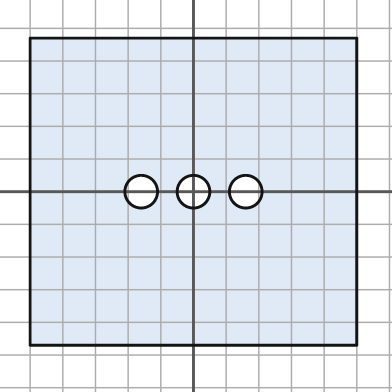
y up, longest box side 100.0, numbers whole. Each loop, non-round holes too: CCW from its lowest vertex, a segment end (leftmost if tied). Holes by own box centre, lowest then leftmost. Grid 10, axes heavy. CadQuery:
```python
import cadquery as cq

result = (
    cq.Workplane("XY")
    .moveTo(-50.0, -47.0)
    .lineTo(50.0, -47.0)
    .lineTo(50.0, 47.0)
    .lineTo(-50.0, 47.0)
    .close()
    .moveTo(-16.0, 0.0)
    .circle(5.0)
    .moveTo(0.0, 0.0)
    .circle(5.0)
    .moveTo(16.0, 0.0)
    .circle(5.0)
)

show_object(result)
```